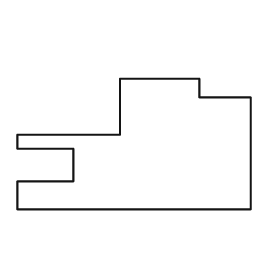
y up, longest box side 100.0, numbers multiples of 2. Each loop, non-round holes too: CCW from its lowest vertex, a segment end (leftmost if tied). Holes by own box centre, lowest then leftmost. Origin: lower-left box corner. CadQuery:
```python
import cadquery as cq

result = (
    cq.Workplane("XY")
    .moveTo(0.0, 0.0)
    .lineTo(100.0, 0.0)
    .lineTo(100.0, 48.0)
    .lineTo(78.0, 48.0)
    .lineTo(78.0, 56.0)
    .lineTo(44.0, 56.0)
    .lineTo(44.0, 32.0)
    .lineTo(0.0, 32.0)
    .lineTo(0.0, 26.0)
    .lineTo(24.0, 26.0)
    .lineTo(24.0, 12.0)
    .lineTo(0.0, 12.0)
    .close()
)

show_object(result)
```